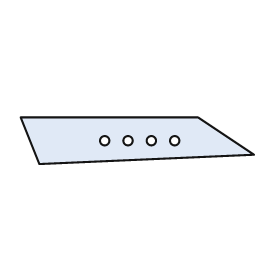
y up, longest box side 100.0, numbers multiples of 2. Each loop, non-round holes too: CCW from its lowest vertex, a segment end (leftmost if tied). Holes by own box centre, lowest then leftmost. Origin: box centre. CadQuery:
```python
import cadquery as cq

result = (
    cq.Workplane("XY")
    .moveTo(-42.0, -10.0)
    .lineTo(50.0, -6.0)
    .lineTo(26.0, 10.0)
    .lineTo(-50.0, 10.0)
    .close()
    .moveTo(-14.0, 0.0)
    .circle(2.0)
    .moveTo(-4.0, 0.0)
    .circle(2.0)
    .moveTo(6.0, 0.0)
    .circle(2.0)
    .moveTo(16.0, 0.0)
    .circle(2.0)
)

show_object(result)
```